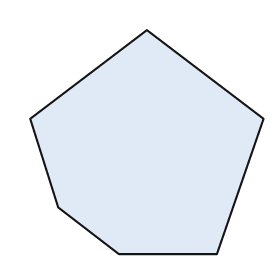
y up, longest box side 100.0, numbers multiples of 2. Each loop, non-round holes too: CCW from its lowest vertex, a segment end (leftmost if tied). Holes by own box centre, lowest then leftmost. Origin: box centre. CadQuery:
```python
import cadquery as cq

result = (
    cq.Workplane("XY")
    .moveTo(-12.0, -48.0)
    .lineTo(30.0, -48.0)
    .lineTo(50.0, 10.0)
    .lineTo(0.0, 48.0)
    .lineTo(-50.0, 10.0)
    .lineTo(-38.0, -28.0)
    .close()
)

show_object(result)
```